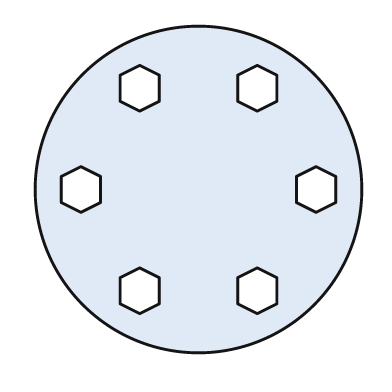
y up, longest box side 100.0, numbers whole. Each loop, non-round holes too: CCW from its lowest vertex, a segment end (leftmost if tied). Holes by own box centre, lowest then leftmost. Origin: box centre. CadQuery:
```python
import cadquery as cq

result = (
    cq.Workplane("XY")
    .moveTo(0.0, 0.0)
    .circle(50.0)
    .moveTo(-18.0, -38.0)
    .lineTo(-12.0, -35.0)
    .lineTo(-12.0, -27.0)
    .lineTo(-18.0, -24.0)
    .lineTo(-24.0, -27.0)
    .lineTo(-24.0, -35.0)
    .close()
    .moveTo(18.0, -38.0)
    .lineTo(24.0, -35.0)
    .lineTo(24.0, -27.0)
    .lineTo(18.0, -24.0)
    .lineTo(12.0, -27.0)
    .lineTo(12.0, -35.0)
    .close()
    .moveTo(-36.0, -7.0)
    .lineTo(-30.0, -4.0)
    .lineTo(-30.0, 4.0)
    .lineTo(-36.0, 7.0)
    .lineTo(-42.0, 4.0)
    .lineTo(-42.0, -4.0)
    .close()
    .moveTo(36.0, -7.0)
    .lineTo(42.0, -4.0)
    .lineTo(42.0, 4.0)
    .lineTo(36.0, 7.0)
    .lineTo(30.0, 4.0)
    .lineTo(30.0, -4.0)
    .close()
    .moveTo(-18.0, 24.0)
    .lineTo(-12.0, 27.0)
    .lineTo(-12.0, 35.0)
    .lineTo(-18.0, 38.0)
    .lineTo(-24.0, 35.0)
    .lineTo(-24.0, 27.0)
    .close()
    .moveTo(18.0, 24.0)
    .lineTo(24.0, 27.0)
    .lineTo(24.0, 35.0)
    .lineTo(18.0, 38.0)
    .lineTo(12.0, 35.0)
    .lineTo(12.0, 27.0)
    .close()
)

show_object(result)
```